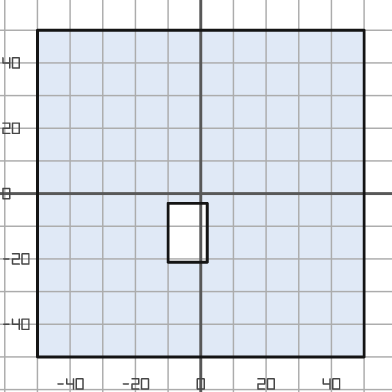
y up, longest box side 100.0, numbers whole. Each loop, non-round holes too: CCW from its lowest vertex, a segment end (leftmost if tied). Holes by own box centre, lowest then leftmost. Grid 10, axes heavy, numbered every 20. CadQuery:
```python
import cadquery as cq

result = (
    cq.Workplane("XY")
    .moveTo(-50.0, -50.0)
    .lineTo(50.0, -50.0)
    .lineTo(50.0, 50.0)
    .lineTo(-50.0, 50.0)
    .close()
    .moveTo(-10.0, -21.0)
    .lineTo(2.0, -21.0)
    .lineTo(2.0, -3.0)
    .lineTo(-10.0, -3.0)
    .close()
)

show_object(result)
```